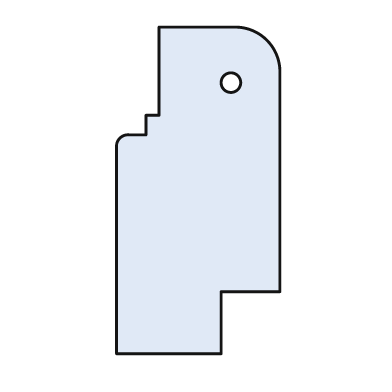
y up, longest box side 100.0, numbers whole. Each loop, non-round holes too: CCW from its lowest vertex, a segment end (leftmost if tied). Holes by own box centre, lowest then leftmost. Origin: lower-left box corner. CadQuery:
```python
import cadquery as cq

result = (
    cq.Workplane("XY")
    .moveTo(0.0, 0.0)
    .lineTo(32.0, 0.0)
    .lineTo(32.0, 19.0)
    .lineTo(50.0, 19.0)
    .lineTo(50.0, 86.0)
    .threePointArc((46.0, 96.0), (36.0, 100.0))
    .lineTo(13.0, 100.0)
    .lineTo(13.0, 73.0)
    .lineTo(9.0, 73.0)
    .lineTo(9.0, 67.0)
    .lineTo(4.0, 67.0)
    .threePointArc((1.0, 66.0), (0.0, 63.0))
    .close()
    .moveTo(35.0, 83.0)
    .circle(3.0)
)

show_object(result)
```